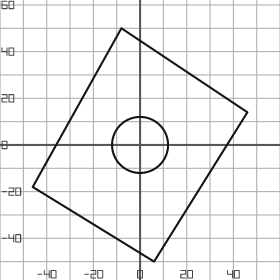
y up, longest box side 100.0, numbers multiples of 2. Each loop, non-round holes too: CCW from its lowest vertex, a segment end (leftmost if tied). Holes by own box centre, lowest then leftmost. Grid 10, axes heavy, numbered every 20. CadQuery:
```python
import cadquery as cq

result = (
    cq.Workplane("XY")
    .moveTo(6.0, -50.0)
    .lineTo(46.0, 14.0)
    .lineTo(-8.0, 50.0)
    .lineTo(-46.0, -18.0)
    .close()
    .moveTo(0.0, 0.0)
    .circle(12.0)
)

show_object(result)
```